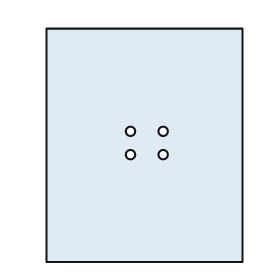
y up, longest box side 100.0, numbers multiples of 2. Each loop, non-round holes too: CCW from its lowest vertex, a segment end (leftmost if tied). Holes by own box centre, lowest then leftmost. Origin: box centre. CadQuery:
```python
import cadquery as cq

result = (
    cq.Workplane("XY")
    .moveTo(-42.0, -50.0)
    .lineTo(42.0, -50.0)
    .lineTo(42.0, 50.0)
    .lineTo(-42.0, 50.0)
    .close()
    .moveTo(-6.0, -4.0)
    .circle(2.0)
    .moveTo(8.0, -4.0)
    .circle(2.0)
    .moveTo(-6.0, 6.0)
    .circle(2.0)
    .moveTo(8.0, 6.0)
    .circle(2.0)
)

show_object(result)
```